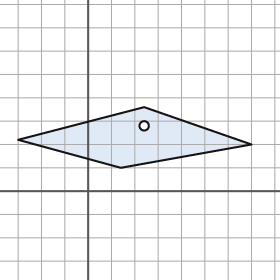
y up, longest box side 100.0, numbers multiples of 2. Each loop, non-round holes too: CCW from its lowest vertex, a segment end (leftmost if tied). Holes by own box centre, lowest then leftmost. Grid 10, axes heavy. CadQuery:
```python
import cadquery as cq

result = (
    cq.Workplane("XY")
    .moveTo(14.0, 10.0)
    .lineTo(70.0, 20.0)
    .lineTo(24.0, 36.0)
    .lineTo(-30.0, 22.0)
    .close()
    .moveTo(24.0, 28.0)
    .circle(2.0)
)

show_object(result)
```